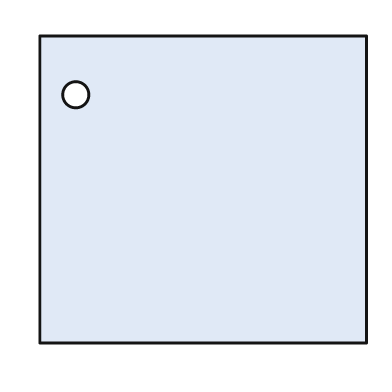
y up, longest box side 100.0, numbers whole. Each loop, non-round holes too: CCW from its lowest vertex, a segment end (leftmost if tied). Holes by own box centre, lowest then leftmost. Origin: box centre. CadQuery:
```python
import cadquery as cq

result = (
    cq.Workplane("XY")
    .moveTo(-50.0, -47.0)
    .lineTo(50.0, -47.0)
    .lineTo(50.0, 47.0)
    .lineTo(-50.0, 47.0)
    .close()
    .moveTo(-39.0, 29.0)
    .circle(4.0)
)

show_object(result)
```